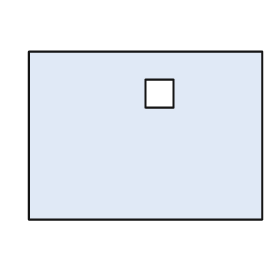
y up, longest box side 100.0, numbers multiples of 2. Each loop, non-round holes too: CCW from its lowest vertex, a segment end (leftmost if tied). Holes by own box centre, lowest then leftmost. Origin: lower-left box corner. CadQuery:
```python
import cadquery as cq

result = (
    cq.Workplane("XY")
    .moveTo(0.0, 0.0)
    .lineTo(100.0, 0.0)
    .lineTo(100.0, 72.0)
    .lineTo(0.0, 72.0)
    .close()
    .moveTo(50.0, 48.0)
    .lineTo(62.0, 48.0)
    .lineTo(62.0, 60.0)
    .lineTo(50.0, 60.0)
    .close()
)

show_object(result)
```